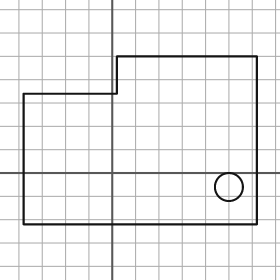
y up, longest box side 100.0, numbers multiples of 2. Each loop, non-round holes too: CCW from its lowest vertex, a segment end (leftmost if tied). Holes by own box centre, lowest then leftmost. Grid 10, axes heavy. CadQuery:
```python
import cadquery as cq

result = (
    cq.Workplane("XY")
    .moveTo(-38.0, -22.0)
    .lineTo(62.0, -22.0)
    .lineTo(62.0, 50.0)
    .lineTo(2.0, 50.0)
    .lineTo(2.0, 34.0)
    .lineTo(-38.0, 34.0)
    .close()
    .moveTo(50.0, -6.0)
    .circle(6.0)
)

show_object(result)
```